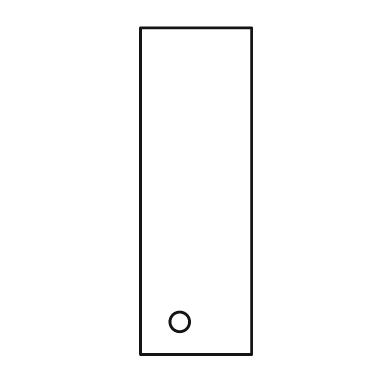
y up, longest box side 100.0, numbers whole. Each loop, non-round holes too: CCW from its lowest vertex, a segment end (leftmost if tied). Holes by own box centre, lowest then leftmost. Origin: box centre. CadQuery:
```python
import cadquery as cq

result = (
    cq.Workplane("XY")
    .moveTo(-17.0, -50.0)
    .lineTo(17.0, -50.0)
    .lineTo(17.0, 50.0)
    .lineTo(-17.0, 50.0)
    .close()
    .moveTo(-5.0, -40.0)
    .circle(3.0)
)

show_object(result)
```